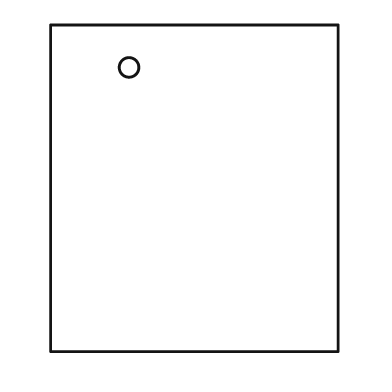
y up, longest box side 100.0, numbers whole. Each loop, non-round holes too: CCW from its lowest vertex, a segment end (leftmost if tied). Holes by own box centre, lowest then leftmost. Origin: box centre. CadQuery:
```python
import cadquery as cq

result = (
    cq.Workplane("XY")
    .moveTo(-44.0, -50.0)
    .lineTo(44.0, -50.0)
    .lineTo(44.0, 50.0)
    .lineTo(-44.0, 50.0)
    .close()
    .moveTo(-20.0, 37.0)
    .circle(3.0)
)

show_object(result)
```